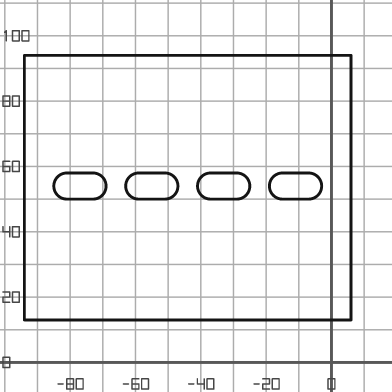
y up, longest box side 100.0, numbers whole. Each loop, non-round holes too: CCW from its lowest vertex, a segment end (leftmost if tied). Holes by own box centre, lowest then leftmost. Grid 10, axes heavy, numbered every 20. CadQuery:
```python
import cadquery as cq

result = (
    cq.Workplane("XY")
    .moveTo(-94.0, 13.0)
    .lineTo(6.0, 13.0)
    .lineTo(6.0, 94.0)
    .lineTo(-94.0, 94.0)
    .close()
    .moveTo(-81.0, 50.0)
    .lineTo(-73.0, 50.0)
    .threePointArc((-69.0, 54.0), (-73.0, 58.0))
    .lineTo(-81.0, 58.0)
    .threePointArc((-85.0, 54.0), (-81.0, 50.0))
    .close()
    .moveTo(-59.0, 50.0)
    .lineTo(-51.0, 50.0)
    .threePointArc((-47.0, 54.0), (-51.0, 58.0))
    .lineTo(-59.0, 58.0)
    .threePointArc((-63.0, 54.0), (-59.0, 50.0))
    .close()
    .moveTo(-37.0, 50.0)
    .lineTo(-29.0, 50.0)
    .threePointArc((-25.0, 54.0), (-29.0, 58.0))
    .lineTo(-37.0, 58.0)
    .threePointArc((-41.0, 54.0), (-37.0, 50.0))
    .close()
    .moveTo(-15.0, 50.0)
    .lineTo(-7.0, 50.0)
    .threePointArc((-3.0, 54.0), (-7.0, 58.0))
    .lineTo(-15.0, 58.0)
    .threePointArc((-19.0, 54.0), (-15.0, 50.0))
    .close()
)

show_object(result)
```